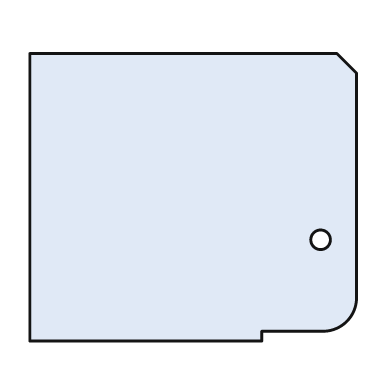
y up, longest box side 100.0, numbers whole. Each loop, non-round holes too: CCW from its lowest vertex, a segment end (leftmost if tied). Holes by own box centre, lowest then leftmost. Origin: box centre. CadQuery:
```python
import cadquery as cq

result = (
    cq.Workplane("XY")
    .moveTo(-50.0, -44.0)
    .lineTo(21.0, -44.0)
    .lineTo(21.0, -41.0)
    .lineTo(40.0, -41.0)
    .threePointArc((47.0, -38.0), (50.0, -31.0))
    .lineTo(50.0, 38.0)
    .lineTo(44.0, 44.0)
    .lineTo(-50.0, 44.0)
    .close()
    .moveTo(39.0, -13.0)
    .circle(3.0)
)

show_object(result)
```